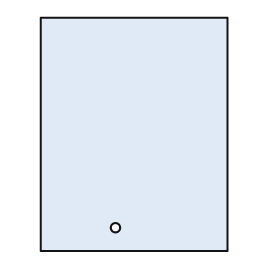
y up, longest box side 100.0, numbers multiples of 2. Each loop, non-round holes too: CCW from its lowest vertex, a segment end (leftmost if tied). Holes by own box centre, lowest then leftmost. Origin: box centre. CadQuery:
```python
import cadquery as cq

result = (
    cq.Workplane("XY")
    .moveTo(-40.0, -50.0)
    .lineTo(40.0, -50.0)
    .lineTo(40.0, 50.0)
    .lineTo(-40.0, 50.0)
    .close()
    .moveTo(-8.0, -40.0)
    .circle(2.0)
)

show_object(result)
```